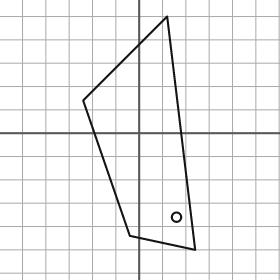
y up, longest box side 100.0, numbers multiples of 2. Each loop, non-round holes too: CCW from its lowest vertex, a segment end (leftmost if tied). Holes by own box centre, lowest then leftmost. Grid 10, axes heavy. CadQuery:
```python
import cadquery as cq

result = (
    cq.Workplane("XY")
    .moveTo(24.0, -50.0)
    .lineTo(12.0, 50.0)
    .lineTo(-24.0, 14.0)
    .lineTo(-4.0, -44.0)
    .close()
    .moveTo(16.0, -36.0)
    .circle(2.0)
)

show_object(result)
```